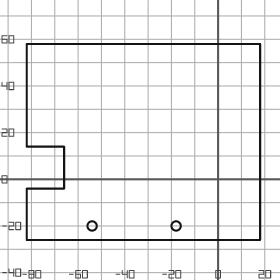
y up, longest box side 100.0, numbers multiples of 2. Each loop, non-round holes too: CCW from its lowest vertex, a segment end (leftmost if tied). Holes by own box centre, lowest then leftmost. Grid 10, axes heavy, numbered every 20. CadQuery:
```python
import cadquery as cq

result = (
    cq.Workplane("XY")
    .moveTo(-82.0, -26.0)
    .lineTo(18.0, -26.0)
    .lineTo(18.0, 58.0)
    .lineTo(-82.0, 58.0)
    .lineTo(-82.0, 14.0)
    .lineTo(-66.0, 14.0)
    .lineTo(-66.0, -4.0)
    .lineTo(-82.0, -4.0)
    .close()
    .moveTo(-54.0, -20.0)
    .circle(2.0)
    .moveTo(-18.0, -20.0)
    .circle(2.0)
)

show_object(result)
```